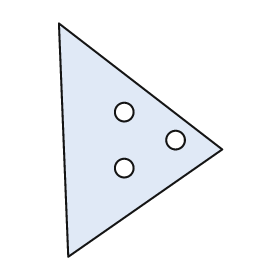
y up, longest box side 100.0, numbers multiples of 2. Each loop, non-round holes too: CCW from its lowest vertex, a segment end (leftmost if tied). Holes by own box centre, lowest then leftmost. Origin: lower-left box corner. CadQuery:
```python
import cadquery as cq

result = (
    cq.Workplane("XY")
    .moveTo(4.0, 0.0)
    .lineTo(70.0, 46.0)
    .lineTo(0.0, 100.0)
    .close()
    .moveTo(28.0, 38.0)
    .circle(4.0)
    .moveTo(50.0, 50.0)
    .circle(4.0)
    .moveTo(28.0, 62.0)
    .circle(4.0)
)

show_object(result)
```